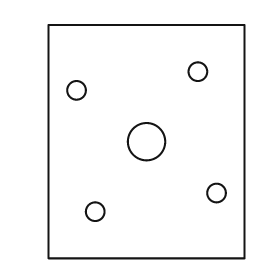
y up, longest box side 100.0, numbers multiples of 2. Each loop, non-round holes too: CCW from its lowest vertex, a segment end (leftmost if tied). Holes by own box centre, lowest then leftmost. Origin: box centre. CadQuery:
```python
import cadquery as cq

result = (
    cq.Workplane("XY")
    .moveTo(-42.0, -50.0)
    .lineTo(42.0, -50.0)
    .lineTo(42.0, 50.0)
    .lineTo(-42.0, 50.0)
    .close()
    .moveTo(-22.0, -30.0)
    .circle(4.0)
    .moveTo(30.0, -22.0)
    .circle(4.0)
    .moveTo(0.0, 0.0)
    .circle(8.0)
    .moveTo(-30.0, 22.0)
    .circle(4.0)
    .moveTo(22.0, 30.0)
    .circle(4.0)
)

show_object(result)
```